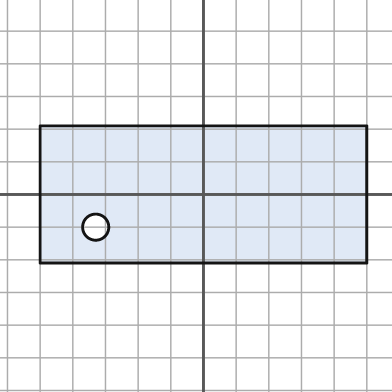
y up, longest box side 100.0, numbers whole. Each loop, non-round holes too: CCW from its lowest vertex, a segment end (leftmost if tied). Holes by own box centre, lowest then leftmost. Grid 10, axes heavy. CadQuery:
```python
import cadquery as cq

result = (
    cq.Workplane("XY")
    .moveTo(-50.0, -21.0)
    .lineTo(50.0, -21.0)
    .lineTo(50.0, 21.0)
    .lineTo(-50.0, 21.0)
    .close()
    .moveTo(-33.0, -10.0)
    .circle(4.0)
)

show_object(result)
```